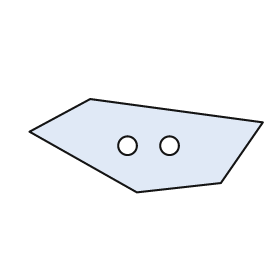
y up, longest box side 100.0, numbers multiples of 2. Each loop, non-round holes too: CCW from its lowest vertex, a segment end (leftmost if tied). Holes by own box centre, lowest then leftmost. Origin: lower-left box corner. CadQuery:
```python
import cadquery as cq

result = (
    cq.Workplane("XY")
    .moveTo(46.0, 0.0)
    .lineTo(82.0, 4.0)
    .lineTo(100.0, 30.0)
    .lineTo(26.0, 40.0)
    .lineTo(0.0, 26.0)
    .close()
    .moveTo(42.0, 20.0)
    .circle(4.0)
    .moveTo(60.0, 20.0)
    .circle(4.0)
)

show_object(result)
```